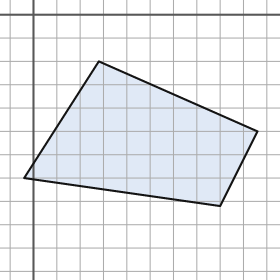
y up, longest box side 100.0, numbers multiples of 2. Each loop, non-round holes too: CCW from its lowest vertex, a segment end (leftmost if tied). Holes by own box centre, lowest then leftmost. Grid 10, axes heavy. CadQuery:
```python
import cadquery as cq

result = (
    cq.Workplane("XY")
    .moveTo(80.0, -82.0)
    .lineTo(96.0, -50.0)
    .lineTo(28.0, -20.0)
    .lineTo(-4.0, -70.0)
    .close()
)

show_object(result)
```